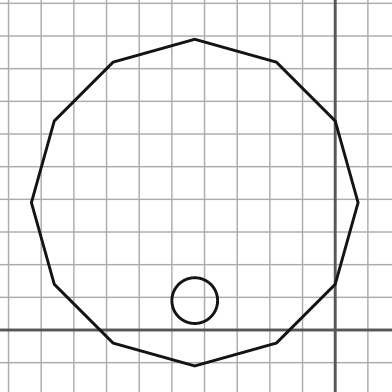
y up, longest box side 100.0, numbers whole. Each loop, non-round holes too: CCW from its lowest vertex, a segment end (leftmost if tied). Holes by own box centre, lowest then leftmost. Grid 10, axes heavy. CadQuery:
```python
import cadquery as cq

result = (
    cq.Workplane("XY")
    .moveTo(-43.0, -11.0)
    .lineTo(-18.0, -4.0)
    .lineTo(0.0, 14.0)
    .lineTo(7.0, 39.0)
    .lineTo(0.0, 64.0)
    .lineTo(-18.0, 82.0)
    .lineTo(-43.0, 89.0)
    .lineTo(-68.0, 82.0)
    .lineTo(-86.0, 64.0)
    .lineTo(-93.0, 39.0)
    .lineTo(-86.0, 14.0)
    .lineTo(-68.0, -4.0)
    .close()
    .moveTo(-43.0, 9.0)
    .circle(7.0)
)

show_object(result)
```